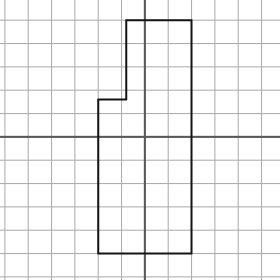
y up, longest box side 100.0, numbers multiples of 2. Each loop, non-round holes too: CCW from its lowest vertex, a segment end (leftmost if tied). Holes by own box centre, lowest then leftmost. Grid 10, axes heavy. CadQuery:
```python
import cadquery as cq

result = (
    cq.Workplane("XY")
    .moveTo(-20.0, -50.0)
    .lineTo(20.0, -50.0)
    .lineTo(20.0, 50.0)
    .lineTo(-8.0, 50.0)
    .lineTo(-8.0, 16.0)
    .lineTo(-20.0, 16.0)
    .close()
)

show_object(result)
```